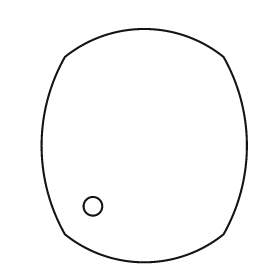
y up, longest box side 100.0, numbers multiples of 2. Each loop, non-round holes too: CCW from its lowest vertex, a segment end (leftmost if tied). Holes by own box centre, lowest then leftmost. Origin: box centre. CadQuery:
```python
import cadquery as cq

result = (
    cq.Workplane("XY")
    .moveTo(-34.0, -38.0)
    .threePointArc((0.0, -50.0), (34.0, -38.0))
    .threePointArc((44.0, 0.0), (34.0, 38.0))
    .threePointArc((0.0, 50.0), (-34.0, 38.0))
    .threePointArc((-44.0, 0.0), (-34.0, -38.0))
    .close()
    .moveTo(-22.0, -26.0)
    .circle(4.0)
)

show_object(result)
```